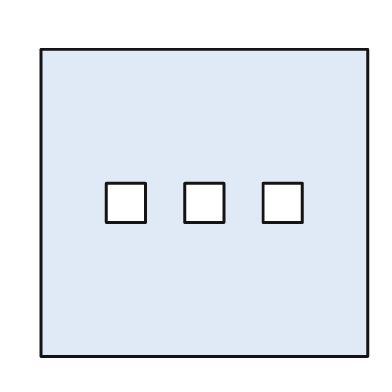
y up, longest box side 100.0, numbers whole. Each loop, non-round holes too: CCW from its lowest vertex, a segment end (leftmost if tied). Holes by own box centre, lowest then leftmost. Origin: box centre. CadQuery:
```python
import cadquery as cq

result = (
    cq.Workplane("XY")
    .moveTo(-50.0, -47.0)
    .lineTo(50.0, -47.0)
    .lineTo(50.0, 47.0)
    .lineTo(-50.0, 47.0)
    .close()
    .moveTo(-30.0, -6.0)
    .lineTo(-18.0, -6.0)
    .lineTo(-18.0, 6.0)
    .lineTo(-30.0, 6.0)
    .close()
    .moveTo(-6.0, -6.0)
    .lineTo(6.0, -6.0)
    .lineTo(6.0, 6.0)
    .lineTo(-6.0, 6.0)
    .close()
    .moveTo(18.0, -6.0)
    .lineTo(30.0, -6.0)
    .lineTo(30.0, 6.0)
    .lineTo(18.0, 6.0)
    .close()
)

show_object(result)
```